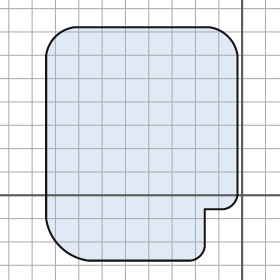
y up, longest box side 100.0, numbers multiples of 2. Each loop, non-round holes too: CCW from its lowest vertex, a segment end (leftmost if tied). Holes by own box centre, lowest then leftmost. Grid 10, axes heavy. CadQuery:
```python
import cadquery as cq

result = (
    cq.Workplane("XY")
    .moveTo(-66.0, -28.0)
    .lineTo(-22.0, -28.0)
    .threePointArc((-18.0, -26.0), (-16.0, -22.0))
    .lineTo(-16.0, -6.0)
    .lineTo(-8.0, -6.0)
    .threePointArc((-4.0, -4.0), (-2.0, 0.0))
    .lineTo(-2.0, 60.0)
    .threePointArc((-6.0, 68.0), (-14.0, 72.0))
    .lineTo(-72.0, 72.0)
    .threePointArc((-80.0, 68.0), (-84.0, 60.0))
    .lineTo(-84.0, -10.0)
    .threePointArc((-78.0, -22.0), (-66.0, -28.0))
    .close()
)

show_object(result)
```